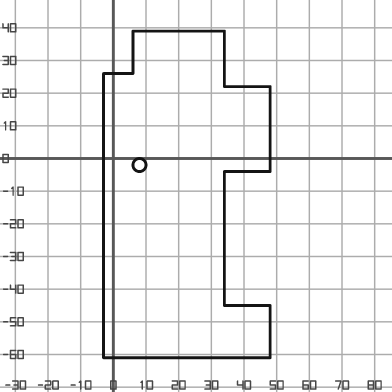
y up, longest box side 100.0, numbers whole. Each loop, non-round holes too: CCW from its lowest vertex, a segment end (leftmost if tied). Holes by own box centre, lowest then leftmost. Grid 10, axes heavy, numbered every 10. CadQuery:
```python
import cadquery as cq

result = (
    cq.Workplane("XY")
    .moveTo(-3.0, -61.0)
    .lineTo(48.0, -61.0)
    .lineTo(48.0, -45.0)
    .lineTo(34.0, -45.0)
    .lineTo(34.0, -4.0)
    .lineTo(48.0, -4.0)
    .lineTo(48.0, 22.0)
    .lineTo(34.0, 22.0)
    .lineTo(34.0, 39.0)
    .lineTo(6.0, 39.0)
    .lineTo(6.0, 26.0)
    .lineTo(-3.0, 26.0)
    .close()
    .moveTo(8.0, -2.0)
    .circle(2.0)
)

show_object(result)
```